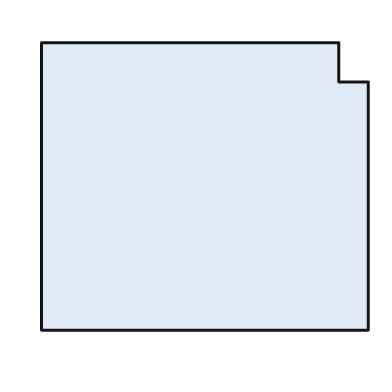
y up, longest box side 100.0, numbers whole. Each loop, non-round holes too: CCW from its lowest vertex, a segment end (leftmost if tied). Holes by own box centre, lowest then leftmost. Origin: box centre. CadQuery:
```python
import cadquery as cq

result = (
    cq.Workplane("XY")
    .moveTo(-50.0, -44.0)
    .lineTo(50.0, -44.0)
    .lineTo(50.0, 32.0)
    .lineTo(41.0, 32.0)
    .lineTo(41.0, 44.0)
    .lineTo(-50.0, 44.0)
    .close()
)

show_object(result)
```